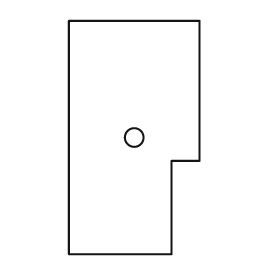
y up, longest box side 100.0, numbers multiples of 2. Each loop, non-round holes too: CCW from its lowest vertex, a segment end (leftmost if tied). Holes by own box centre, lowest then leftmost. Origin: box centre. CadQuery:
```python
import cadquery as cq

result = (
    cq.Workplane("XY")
    .moveTo(-28.0, -50.0)
    .lineTo(16.0, -50.0)
    .lineTo(16.0, -10.0)
    .lineTo(28.0, -10.0)
    .lineTo(28.0, 50.0)
    .lineTo(-28.0, 50.0)
    .close()
    .moveTo(0.0, 0.0)
    .circle(4.0)
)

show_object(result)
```